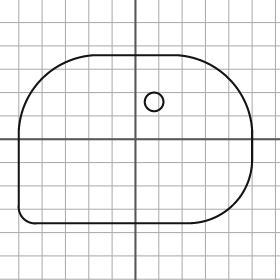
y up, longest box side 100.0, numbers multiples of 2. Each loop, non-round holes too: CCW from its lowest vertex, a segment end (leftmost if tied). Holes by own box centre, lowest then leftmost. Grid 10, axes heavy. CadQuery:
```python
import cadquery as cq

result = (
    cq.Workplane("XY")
    .moveTo(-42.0, -36.0)
    .lineTo(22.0, -36.0)
    .threePointArc((42.0, -28.0), (50.0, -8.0))
    .lineTo(50.0, 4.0)
    .threePointArc((40.0, 26.0), (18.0, 36.0))
    .lineTo(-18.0, 36.0)
    .threePointArc((-40.0, 26.0), (-50.0, 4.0))
    .lineTo(-50.0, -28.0)
    .threePointArc((-48.0, -34.0), (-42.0, -36.0))
    .close()
    .moveTo(8.0, 16.0)
    .circle(4.0)
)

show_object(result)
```